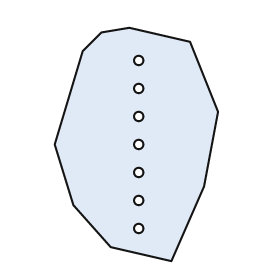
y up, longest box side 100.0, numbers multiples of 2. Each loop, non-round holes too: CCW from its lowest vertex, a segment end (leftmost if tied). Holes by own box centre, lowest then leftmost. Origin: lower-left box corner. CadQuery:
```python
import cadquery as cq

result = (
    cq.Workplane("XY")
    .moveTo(50.0, 0.0)
    .lineTo(64.0, 32.0)
    .lineTo(70.0, 64.0)
    .lineTo(58.0, 94.0)
    .lineTo(32.0, 100.0)
    .lineTo(20.0, 98.0)
    .lineTo(12.0, 90.0)
    .lineTo(0.0, 50.0)
    .lineTo(8.0, 24.0)
    .lineTo(24.0, 6.0)
    .close()
    .moveTo(36.0, 14.0)
    .circle(2.0)
    .moveTo(36.0, 26.0)
    .circle(2.0)
    .moveTo(36.0, 38.0)
    .circle(2.0)
    .moveTo(36.0, 50.0)
    .circle(2.0)
    .moveTo(36.0, 62.0)
    .circle(2.0)
    .moveTo(36.0, 74.0)
    .circle(2.0)
    .moveTo(36.0, 86.0)
    .circle(2.0)
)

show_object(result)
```